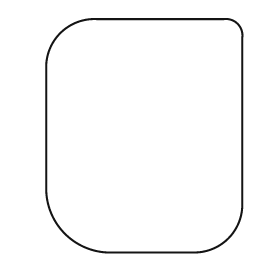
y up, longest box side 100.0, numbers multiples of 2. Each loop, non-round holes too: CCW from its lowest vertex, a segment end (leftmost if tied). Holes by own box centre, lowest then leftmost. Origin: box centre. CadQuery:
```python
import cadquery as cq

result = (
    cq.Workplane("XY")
    .moveTo(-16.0, -50.0)
    .lineTo(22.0, -50.0)
    .threePointArc((36.0, -44.0), (42.0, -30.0))
    .lineTo(42.0, 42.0)
    .threePointArc((40.0, 48.0), (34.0, 50.0))
    .lineTo(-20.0, 50.0)
    .threePointArc((-36.0, 44.0), (-42.0, 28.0))
    .lineTo(-42.0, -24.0)
    .threePointArc((-34.0, -42.0), (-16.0, -50.0))
    .close()
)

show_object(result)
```